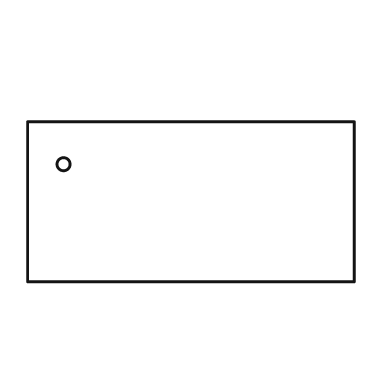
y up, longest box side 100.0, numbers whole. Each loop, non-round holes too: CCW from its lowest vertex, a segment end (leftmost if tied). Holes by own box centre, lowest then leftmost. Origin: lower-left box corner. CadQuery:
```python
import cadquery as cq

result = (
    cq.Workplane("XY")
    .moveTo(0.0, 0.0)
    .lineTo(100.0, 0.0)
    .lineTo(100.0, 49.0)
    .lineTo(0.0, 49.0)
    .close()
    .moveTo(11.0, 36.0)
    .circle(2.0)
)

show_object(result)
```